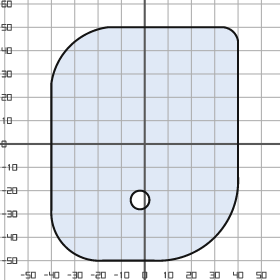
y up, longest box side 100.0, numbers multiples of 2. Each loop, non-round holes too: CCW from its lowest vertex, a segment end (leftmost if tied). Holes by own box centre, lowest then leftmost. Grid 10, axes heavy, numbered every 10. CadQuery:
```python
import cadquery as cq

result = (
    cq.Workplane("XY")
    .moveTo(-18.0, -50.0)
    .lineTo(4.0, -50.0)
    .threePointArc((30.0, -40.0), (40.0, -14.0))
    .lineTo(40.0, 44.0)
    .threePointArc((38.0, 48.0), (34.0, 50.0))
    .lineTo(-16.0, 50.0)
    .threePointArc((-32.0, 42.0), (-40.0, 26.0))
    .lineTo(-40.0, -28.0)
    .threePointArc((-34.0, -44.0), (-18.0, -50.0))
    .close()
    .moveTo(-2.0, -24.0)
    .circle(4.0)
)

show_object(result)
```